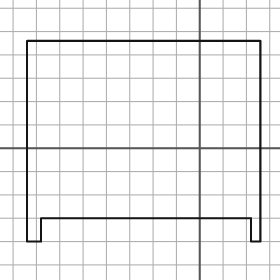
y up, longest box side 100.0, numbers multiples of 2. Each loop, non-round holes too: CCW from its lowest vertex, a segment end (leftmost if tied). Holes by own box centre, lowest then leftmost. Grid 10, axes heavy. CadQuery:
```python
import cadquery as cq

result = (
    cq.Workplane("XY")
    .moveTo(-74.0, -40.0)
    .lineTo(-68.0, -40.0)
    .lineTo(-68.0, -30.0)
    .lineTo(22.0, -30.0)
    .lineTo(22.0, -40.0)
    .lineTo(26.0, -40.0)
    .lineTo(26.0, 46.0)
    .lineTo(-74.0, 46.0)
    .close()
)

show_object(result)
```